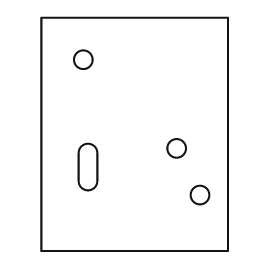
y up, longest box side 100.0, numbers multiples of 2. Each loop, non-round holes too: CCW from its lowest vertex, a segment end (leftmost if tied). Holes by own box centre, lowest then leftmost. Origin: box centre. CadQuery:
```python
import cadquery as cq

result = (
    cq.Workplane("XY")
    .moveTo(-40.0, -50.0)
    .lineTo(40.0, -50.0)
    .lineTo(40.0, 50.0)
    .lineTo(-40.0, 50.0)
    .close()
    .moveTo(28.0, -26.0)
    .circle(4.0)
    .moveTo(-24.0, -20.0)
    .threePointArc((-20.0, -24.0), (-16.0, -20.0))
    .lineTo(-16.0, -8.0)
    .threePointArc((-20.0, -4.0), (-24.0, -8.0))
    .close()
    .moveTo(18.0, -6.0)
    .circle(4.0)
    .moveTo(-22.0, 32.0)
    .circle(4.0)
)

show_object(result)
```